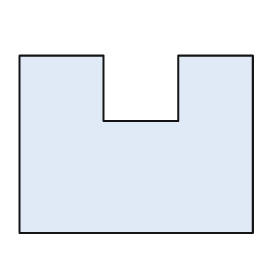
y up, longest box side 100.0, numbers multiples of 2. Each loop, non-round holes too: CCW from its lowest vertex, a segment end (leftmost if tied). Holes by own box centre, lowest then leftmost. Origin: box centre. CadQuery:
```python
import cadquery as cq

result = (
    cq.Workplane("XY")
    .moveTo(-50.0, -38.0)
    .lineTo(50.0, -38.0)
    .lineTo(50.0, 38.0)
    .lineTo(18.0, 38.0)
    .lineTo(18.0, 10.0)
    .lineTo(-14.0, 10.0)
    .lineTo(-14.0, 38.0)
    .lineTo(-50.0, 38.0)
    .close()
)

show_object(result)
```